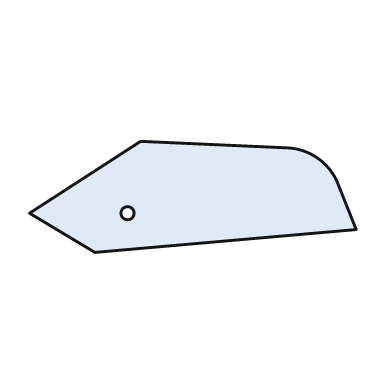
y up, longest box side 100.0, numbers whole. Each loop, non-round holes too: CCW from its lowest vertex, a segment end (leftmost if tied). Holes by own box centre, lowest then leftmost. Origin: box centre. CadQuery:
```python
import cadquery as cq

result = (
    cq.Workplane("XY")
    .moveTo(-30.0, -17.0)
    .lineTo(50.0, -10.0)
    .lineTo(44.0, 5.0)
    .threePointArc((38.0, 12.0), (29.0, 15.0))
    .lineTo(-16.0, 17.0)
    .lineTo(-50.0, -5.0)
    .close()
    .moveTo(-20.0, -5.0)
    .circle(2.0)
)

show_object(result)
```